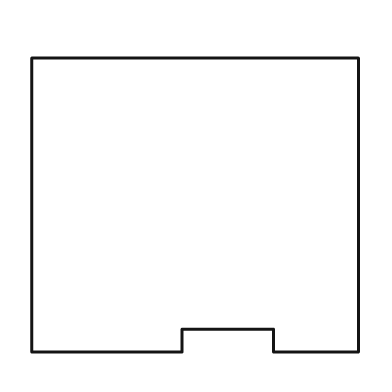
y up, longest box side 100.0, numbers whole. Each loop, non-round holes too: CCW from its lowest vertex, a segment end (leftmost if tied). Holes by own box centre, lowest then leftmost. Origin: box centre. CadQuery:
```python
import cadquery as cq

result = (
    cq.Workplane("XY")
    .moveTo(-50.0, -45.0)
    .lineTo(-4.0, -45.0)
    .lineTo(-4.0, -38.0)
    .lineTo(24.0, -38.0)
    .lineTo(24.0, -45.0)
    .lineTo(50.0, -45.0)
    .lineTo(50.0, 45.0)
    .lineTo(-50.0, 45.0)
    .close()
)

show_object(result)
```